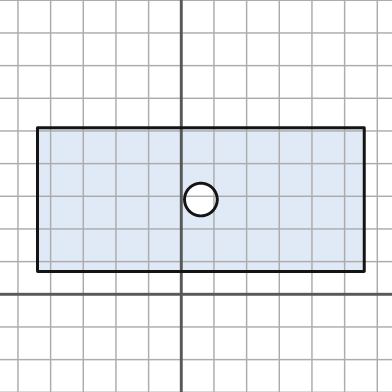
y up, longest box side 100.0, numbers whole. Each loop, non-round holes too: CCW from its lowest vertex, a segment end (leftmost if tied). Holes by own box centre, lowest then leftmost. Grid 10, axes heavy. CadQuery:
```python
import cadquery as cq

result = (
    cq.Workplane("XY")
    .moveTo(-44.0, 7.0)
    .lineTo(56.0, 7.0)
    .lineTo(56.0, 51.0)
    .lineTo(-44.0, 51.0)
    .close()
    .moveTo(6.0, 29.0)
    .circle(5.0)
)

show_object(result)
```